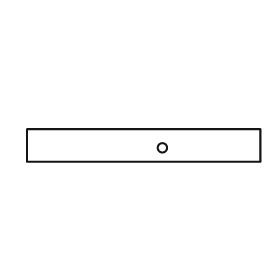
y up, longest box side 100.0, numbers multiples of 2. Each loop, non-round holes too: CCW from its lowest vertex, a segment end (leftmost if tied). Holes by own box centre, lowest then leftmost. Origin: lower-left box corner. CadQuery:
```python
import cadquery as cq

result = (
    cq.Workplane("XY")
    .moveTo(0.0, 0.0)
    .lineTo(100.0, 0.0)
    .lineTo(100.0, 14.0)
    .lineTo(0.0, 14.0)
    .close()
    .moveTo(58.0, 6.0)
    .circle(2.0)
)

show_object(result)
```